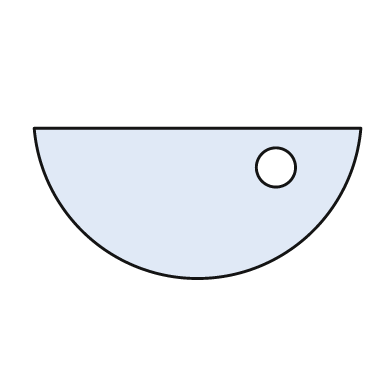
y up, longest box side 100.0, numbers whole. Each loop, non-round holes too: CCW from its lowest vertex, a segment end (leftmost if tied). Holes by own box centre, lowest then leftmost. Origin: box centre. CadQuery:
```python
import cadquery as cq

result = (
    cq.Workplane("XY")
    .moveTo(-50.0, 23.0)
    .threePointArc((0.0, -23.0), (50.0, 23.0))
    .close()
    .moveTo(24.0, 11.0)
    .circle(6.0)
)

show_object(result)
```